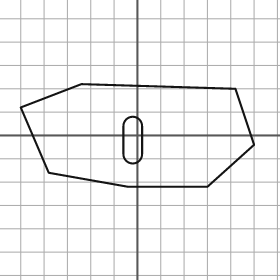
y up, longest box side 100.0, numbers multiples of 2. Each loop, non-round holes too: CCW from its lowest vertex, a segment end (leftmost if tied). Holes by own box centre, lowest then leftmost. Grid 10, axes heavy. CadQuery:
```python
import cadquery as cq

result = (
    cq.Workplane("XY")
    .moveTo(-4.0, -22.0)
    .lineTo(30.0, -22.0)
    .lineTo(50.0, -4.0)
    .lineTo(42.0, 20.0)
    .lineTo(-24.0, 22.0)
    .lineTo(-50.0, 12.0)
    .lineTo(-38.0, -16.0)
    .close()
    .moveTo(-6.0, -8.0)
    .threePointArc((-2.0, -12.0), (2.0, -8.0))
    .lineTo(2.0, 4.0)
    .threePointArc((-2.0, 8.0), (-6.0, 4.0))
    .close()
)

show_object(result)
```